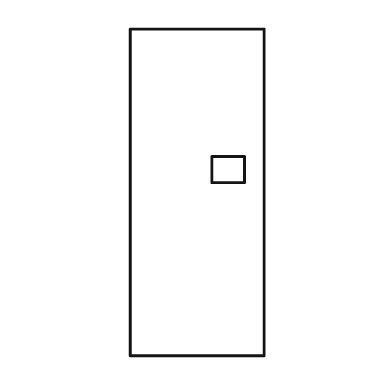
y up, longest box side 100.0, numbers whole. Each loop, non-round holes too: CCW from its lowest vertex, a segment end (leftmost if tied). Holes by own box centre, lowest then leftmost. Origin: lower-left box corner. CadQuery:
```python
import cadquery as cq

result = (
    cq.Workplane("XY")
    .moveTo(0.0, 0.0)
    .lineTo(41.0, 0.0)
    .lineTo(41.0, 100.0)
    .lineTo(0.0, 100.0)
    .close()
    .moveTo(25.0, 53.0)
    .lineTo(35.0, 53.0)
    .lineTo(35.0, 61.0)
    .lineTo(25.0, 61.0)
    .close()
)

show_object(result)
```